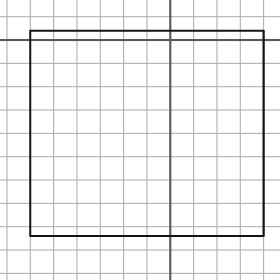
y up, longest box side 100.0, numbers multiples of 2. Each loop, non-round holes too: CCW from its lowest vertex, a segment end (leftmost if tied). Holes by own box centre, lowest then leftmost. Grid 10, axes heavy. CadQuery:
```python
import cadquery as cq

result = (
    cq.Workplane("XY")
    .moveTo(-60.0, -84.0)
    .lineTo(40.0, -84.0)
    .lineTo(40.0, 4.0)
    .lineTo(-60.0, 4.0)
    .close()
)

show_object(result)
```